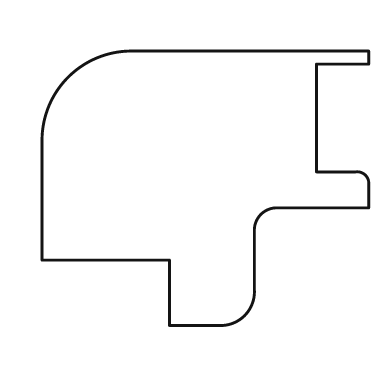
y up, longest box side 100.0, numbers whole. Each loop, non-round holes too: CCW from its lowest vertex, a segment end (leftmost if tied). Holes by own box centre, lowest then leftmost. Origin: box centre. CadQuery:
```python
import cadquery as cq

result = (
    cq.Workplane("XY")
    .moveTo(-11.0, -42.0)
    .lineTo(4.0, -42.0)
    .threePointArc((12.0, -39.0), (15.0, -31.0))
    .lineTo(15.0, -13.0)
    .threePointArc((17.0, -8.0), (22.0, -6.0))
    .lineTo(50.0, -6.0)
    .lineTo(50.0, 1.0)
    .threePointArc((49.0, 4.0), (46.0, 5.0))
    .lineTo(34.0, 5.0)
    .lineTo(34.0, 38.0)
    .lineTo(50.0, 38.0)
    .lineTo(50.0, 42.0)
    .lineTo(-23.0, 42.0)
    .threePointArc((-42.0, 34.0), (-50.0, 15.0))
    .lineTo(-50.0, -22.0)
    .lineTo(-11.0, -22.0)
    .close()
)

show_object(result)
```